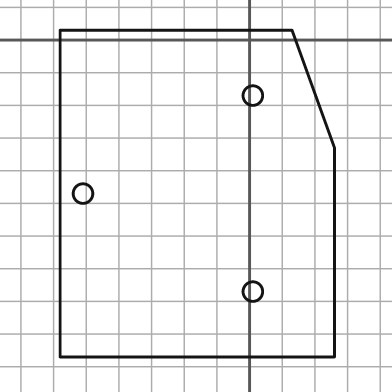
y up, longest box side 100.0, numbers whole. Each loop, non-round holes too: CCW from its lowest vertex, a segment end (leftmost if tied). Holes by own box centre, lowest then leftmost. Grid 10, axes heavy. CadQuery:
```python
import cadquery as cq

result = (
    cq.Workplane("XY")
    .moveTo(-58.0, -97.0)
    .lineTo(26.0, -97.0)
    .lineTo(26.0, -33.0)
    .lineTo(13.0, 3.0)
    .lineTo(-58.0, 3.0)
    .close()
    .moveTo(1.0, -77.0)
    .circle(3.0)
    .moveTo(-51.0, -47.0)
    .circle(3.0)
    .moveTo(1.0, -17.0)
    .circle(3.0)
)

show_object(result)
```